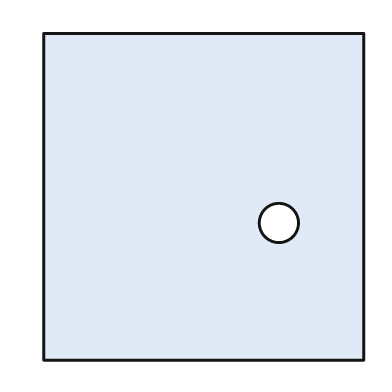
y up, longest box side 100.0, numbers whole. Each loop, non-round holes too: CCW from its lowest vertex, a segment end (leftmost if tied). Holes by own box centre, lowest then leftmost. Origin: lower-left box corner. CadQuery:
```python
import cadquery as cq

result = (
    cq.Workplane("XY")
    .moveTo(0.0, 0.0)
    .lineTo(98.0, 0.0)
    .lineTo(98.0, 100.0)
    .lineTo(0.0, 100.0)
    .close()
    .moveTo(72.0, 42.0)
    .circle(6.0)
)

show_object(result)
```